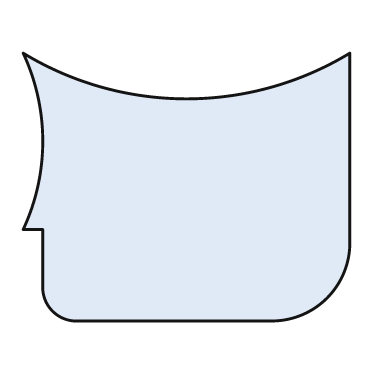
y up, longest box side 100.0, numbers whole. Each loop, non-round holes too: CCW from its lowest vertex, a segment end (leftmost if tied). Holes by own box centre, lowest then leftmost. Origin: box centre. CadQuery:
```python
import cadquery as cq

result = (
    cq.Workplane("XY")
    .moveTo(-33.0, -41.0)
    .lineTo(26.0, -41.0)
    .threePointArc((43.0, -34.0), (50.0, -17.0))
    .lineTo(50.0, 41.0)
    .threePointArc((0.0, 27.0), (-50.0, 41.0))
    .threePointArc((-44.0, 14.0), (-50.0, -13.0))
    .lineTo(-44.0, -13.0)
    .lineTo(-44.0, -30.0)
    .threePointArc((-41.0, -38.0), (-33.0, -41.0))
    .close()
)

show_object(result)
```